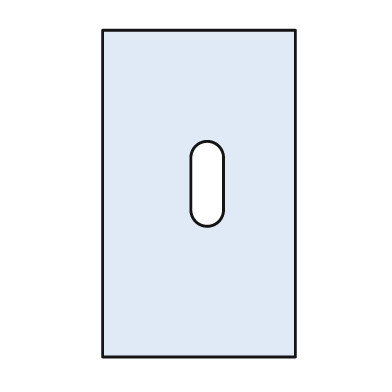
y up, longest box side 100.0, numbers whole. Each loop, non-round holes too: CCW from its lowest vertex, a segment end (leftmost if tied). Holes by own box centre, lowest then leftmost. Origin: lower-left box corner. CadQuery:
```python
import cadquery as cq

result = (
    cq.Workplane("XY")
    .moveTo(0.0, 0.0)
    .lineTo(59.0, 0.0)
    .lineTo(59.0, 100.0)
    .lineTo(0.0, 100.0)
    .close()
    .moveTo(27.0, 45.0)
    .threePointArc((32.0, 40.0), (37.0, 45.0))
    .lineTo(37.0, 61.0)
    .threePointArc((32.0, 66.0), (27.0, 61.0))
    .close()
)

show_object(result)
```